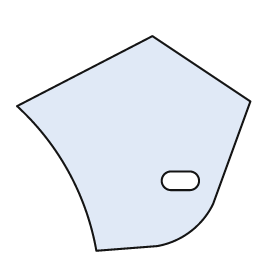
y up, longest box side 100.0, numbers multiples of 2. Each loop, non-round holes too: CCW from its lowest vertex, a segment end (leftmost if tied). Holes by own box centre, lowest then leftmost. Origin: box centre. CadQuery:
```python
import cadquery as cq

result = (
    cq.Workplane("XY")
    .moveTo(-16.0, -46.0)
    .lineTo(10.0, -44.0)
    .threePointArc((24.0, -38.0), (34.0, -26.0))
    .lineTo(50.0, 18.0)
    .lineTo(8.0, 46.0)
    .lineTo(-50.0, 16.0)
    .threePointArc((-28.0, -12.0), (-16.0, -46.0))
    .close()
    .moveTo(16.0, -20.0)
    .lineTo(24.0, -20.0)
    .threePointArc((28.0, -16.0), (24.0, -12.0))
    .lineTo(16.0, -12.0)
    .threePointArc((12.0, -16.0), (16.0, -20.0))
    .close()
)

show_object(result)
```